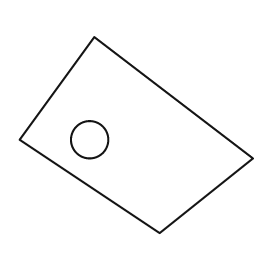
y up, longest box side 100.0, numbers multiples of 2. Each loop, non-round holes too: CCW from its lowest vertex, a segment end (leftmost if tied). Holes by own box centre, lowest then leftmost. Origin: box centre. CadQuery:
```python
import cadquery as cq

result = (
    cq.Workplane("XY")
    .moveTo(10.0, -42.0)
    .lineTo(50.0, -10.0)
    .lineTo(-18.0, 42.0)
    .lineTo(-50.0, -2.0)
    .close()
    .moveTo(-20.0, -2.0)
    .circle(8.0)
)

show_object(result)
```